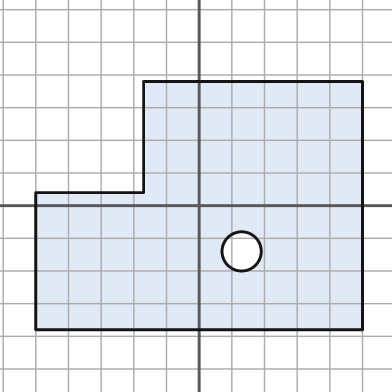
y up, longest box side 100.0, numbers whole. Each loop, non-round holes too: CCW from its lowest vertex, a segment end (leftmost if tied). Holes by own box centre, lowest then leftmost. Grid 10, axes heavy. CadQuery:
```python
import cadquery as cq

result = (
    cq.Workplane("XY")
    .moveTo(-50.0, -38.0)
    .lineTo(50.0, -38.0)
    .lineTo(50.0, 38.0)
    .lineTo(-17.0, 38.0)
    .lineTo(-17.0, 4.0)
    .lineTo(-50.0, 4.0)
    .close()
    .moveTo(13.0, -14.0)
    .circle(6.0)
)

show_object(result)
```